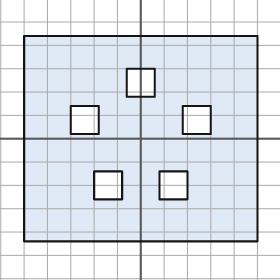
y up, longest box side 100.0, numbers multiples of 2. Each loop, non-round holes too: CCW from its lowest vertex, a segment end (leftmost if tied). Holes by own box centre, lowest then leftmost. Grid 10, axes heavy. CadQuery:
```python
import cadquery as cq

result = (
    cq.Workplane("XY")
    .moveTo(-50.0, -44.0)
    .lineTo(50.0, -44.0)
    .lineTo(50.0, 44.0)
    .lineTo(-50.0, 44.0)
    .close()
    .moveTo(-20.0, -26.0)
    .lineTo(-8.0, -26.0)
    .lineTo(-8.0, -14.0)
    .lineTo(-20.0, -14.0)
    .close()
    .moveTo(8.0, -26.0)
    .lineTo(20.0, -26.0)
    .lineTo(20.0, -14.0)
    .lineTo(8.0, -14.0)
    .close()
    .moveTo(-30.0, 2.0)
    .lineTo(-18.0, 2.0)
    .lineTo(-18.0, 14.0)
    .lineTo(-30.0, 14.0)
    .close()
    .moveTo(18.0, 2.0)
    .lineTo(30.0, 2.0)
    .lineTo(30.0, 14.0)
    .lineTo(18.0, 14.0)
    .close()
    .moveTo(-6.0, 18.0)
    .lineTo(6.0, 18.0)
    .lineTo(6.0, 30.0)
    .lineTo(-6.0, 30.0)
    .close()
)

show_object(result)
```